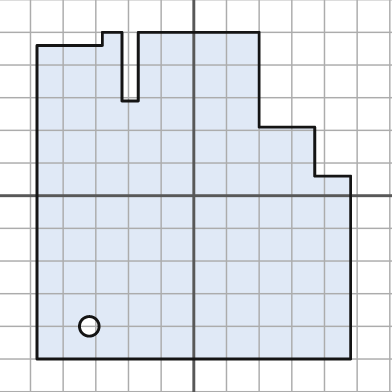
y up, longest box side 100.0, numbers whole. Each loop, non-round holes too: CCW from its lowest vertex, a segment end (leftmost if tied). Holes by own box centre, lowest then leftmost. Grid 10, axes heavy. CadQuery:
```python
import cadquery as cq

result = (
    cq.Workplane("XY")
    .moveTo(-48.0, -50.0)
    .lineTo(48.0, -50.0)
    .lineTo(48.0, 6.0)
    .lineTo(37.0, 6.0)
    .lineTo(37.0, 21.0)
    .lineTo(20.0, 21.0)
    .lineTo(20.0, 50.0)
    .lineTo(-17.0, 50.0)
    .lineTo(-17.0, 29.0)
    .lineTo(-22.0, 29.0)
    .lineTo(-22.0, 50.0)
    .lineTo(-28.0, 50.0)
    .lineTo(-28.0, 46.0)
    .lineTo(-48.0, 46.0)
    .close()
    .moveTo(-32.0, -40.0)
    .circle(3.0)
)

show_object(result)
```